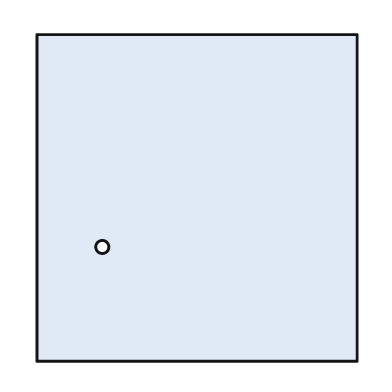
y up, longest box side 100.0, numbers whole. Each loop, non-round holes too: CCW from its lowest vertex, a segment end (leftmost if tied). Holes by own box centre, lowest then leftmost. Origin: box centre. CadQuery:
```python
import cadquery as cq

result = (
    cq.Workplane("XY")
    .moveTo(-49.0, -50.0)
    .lineTo(49.0, -50.0)
    .lineTo(49.0, 50.0)
    .lineTo(-49.0, 50.0)
    .close()
    .moveTo(-29.0, -15.0)
    .circle(2.0)
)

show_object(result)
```